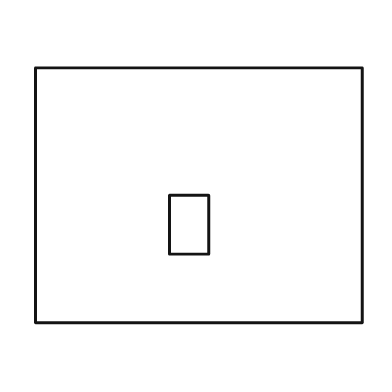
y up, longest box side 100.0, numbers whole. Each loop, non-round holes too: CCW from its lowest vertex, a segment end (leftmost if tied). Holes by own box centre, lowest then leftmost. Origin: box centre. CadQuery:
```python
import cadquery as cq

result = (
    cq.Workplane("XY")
    .moveTo(-50.0, -39.0)
    .lineTo(50.0, -39.0)
    .lineTo(50.0, 39.0)
    .lineTo(-50.0, 39.0)
    .close()
    .moveTo(-9.0, -18.0)
    .lineTo(3.0, -18.0)
    .lineTo(3.0, 0.0)
    .lineTo(-9.0, 0.0)
    .close()
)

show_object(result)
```